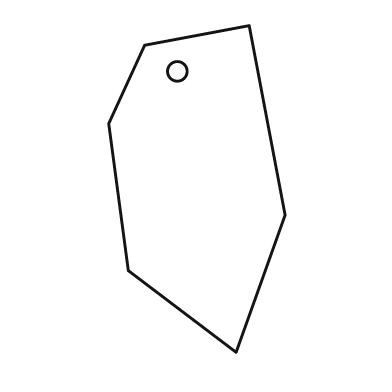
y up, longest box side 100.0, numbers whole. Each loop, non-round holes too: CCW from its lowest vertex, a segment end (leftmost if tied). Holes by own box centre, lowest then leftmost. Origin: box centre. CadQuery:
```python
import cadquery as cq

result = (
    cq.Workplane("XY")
    .moveTo(12.0, -50.0)
    .lineTo(27.0, -8.0)
    .lineTo(16.0, 50.0)
    .lineTo(-16.0, 44.0)
    .lineTo(-27.0, 20.0)
    .lineTo(-21.0, -25.0)
    .close()
    .moveTo(-6.0, 36.0)
    .circle(3.0)
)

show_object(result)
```